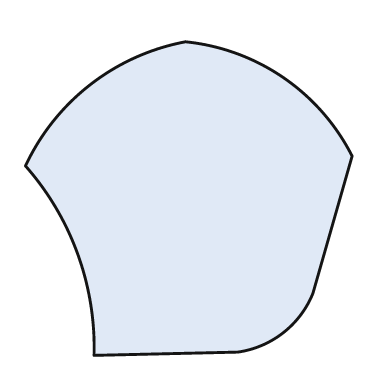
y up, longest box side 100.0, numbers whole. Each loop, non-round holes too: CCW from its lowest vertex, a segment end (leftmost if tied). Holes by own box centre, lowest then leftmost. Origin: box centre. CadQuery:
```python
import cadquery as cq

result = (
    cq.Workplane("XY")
    .moveTo(-29.0, -48.0)
    .lineTo(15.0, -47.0)
    .threePointArc((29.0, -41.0), (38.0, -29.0))
    .lineTo(50.0, 13.0)
    .threePointArc((29.0, 37.0), (-1.0, 48.0))
    .threePointArc((-30.0, 35.0), (-50.0, 10.0))
    .threePointArc((-34.0, -17.0), (-29.0, -48.0))
    .close()
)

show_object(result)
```